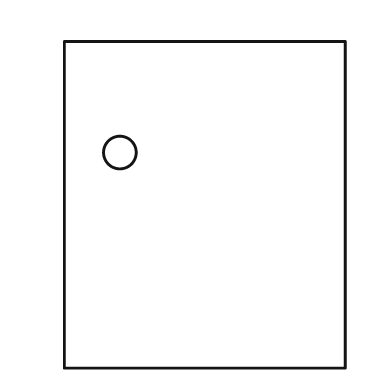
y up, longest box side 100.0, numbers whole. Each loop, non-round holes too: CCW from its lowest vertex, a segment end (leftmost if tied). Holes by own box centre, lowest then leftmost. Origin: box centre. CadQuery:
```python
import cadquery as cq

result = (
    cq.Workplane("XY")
    .moveTo(-43.0, -50.0)
    .lineTo(43.0, -50.0)
    .lineTo(43.0, 50.0)
    .lineTo(-43.0, 50.0)
    .close()
    .moveTo(-26.0, 16.0)
    .circle(5.0)
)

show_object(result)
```